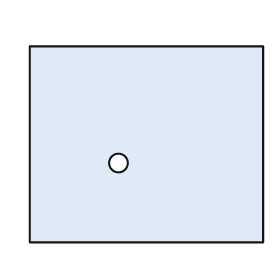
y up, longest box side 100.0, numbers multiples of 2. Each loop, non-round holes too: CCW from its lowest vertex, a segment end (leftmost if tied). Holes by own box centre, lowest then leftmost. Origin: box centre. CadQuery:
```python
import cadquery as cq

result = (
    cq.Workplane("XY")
    .moveTo(-50.0, -42.0)
    .lineTo(50.0, -42.0)
    .lineTo(50.0, 42.0)
    .lineTo(-50.0, 42.0)
    .close()
    .moveTo(-12.0, -8.0)
    .circle(4.0)
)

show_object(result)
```